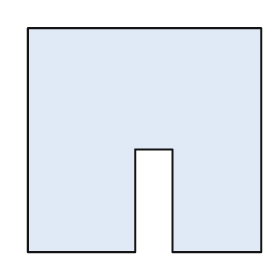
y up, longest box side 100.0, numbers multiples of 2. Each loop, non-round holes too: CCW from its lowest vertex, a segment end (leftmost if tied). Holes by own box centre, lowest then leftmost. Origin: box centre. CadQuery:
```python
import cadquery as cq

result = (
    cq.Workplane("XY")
    .moveTo(-50.0, -48.0)
    .lineTo(-4.0, -48.0)
    .lineTo(-4.0, -4.0)
    .lineTo(12.0, -4.0)
    .lineTo(12.0, -48.0)
    .lineTo(50.0, -48.0)
    .lineTo(50.0, 48.0)
    .lineTo(-50.0, 48.0)
    .close()
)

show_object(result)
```